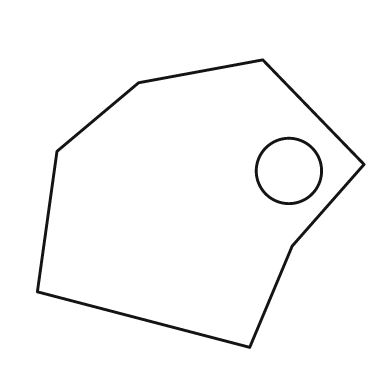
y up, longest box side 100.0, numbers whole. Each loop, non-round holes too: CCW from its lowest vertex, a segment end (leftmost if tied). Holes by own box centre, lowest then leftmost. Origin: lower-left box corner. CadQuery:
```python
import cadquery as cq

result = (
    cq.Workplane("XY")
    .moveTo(65.0, 0.0)
    .lineTo(78.0, 31.0)
    .lineTo(100.0, 56.0)
    .lineTo(69.0, 88.0)
    .lineTo(31.0, 81.0)
    .lineTo(6.0, 60.0)
    .lineTo(0.0, 17.0)
    .close()
    .moveTo(77.0, 54.0)
    .circle(10.0)
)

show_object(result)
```